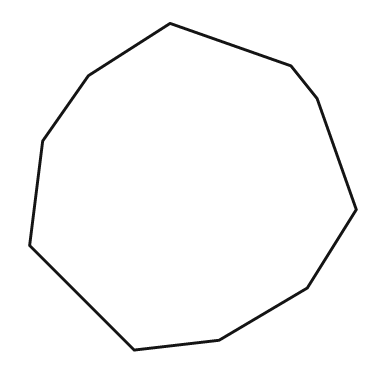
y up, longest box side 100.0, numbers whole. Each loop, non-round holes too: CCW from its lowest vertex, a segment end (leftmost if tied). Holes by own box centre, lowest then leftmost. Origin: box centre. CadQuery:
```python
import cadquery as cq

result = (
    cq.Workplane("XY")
    .moveTo(-18.0, -50.0)
    .lineTo(8.0, -47.0)
    .lineTo(35.0, -31.0)
    .lineTo(50.0, -7.0)
    .lineTo(38.0, 27.0)
    .lineTo(30.0, 37.0)
    .lineTo(-7.0, 50.0)
    .lineTo(-32.0, 34.0)
    .lineTo(-46.0, 14.0)
    .lineTo(-50.0, -18.0)
    .close()
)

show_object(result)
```